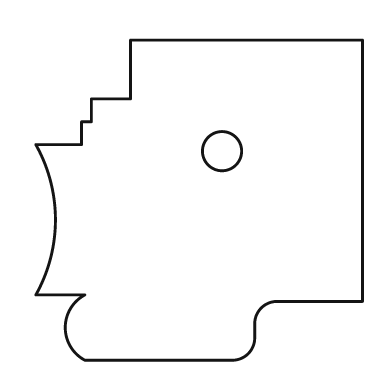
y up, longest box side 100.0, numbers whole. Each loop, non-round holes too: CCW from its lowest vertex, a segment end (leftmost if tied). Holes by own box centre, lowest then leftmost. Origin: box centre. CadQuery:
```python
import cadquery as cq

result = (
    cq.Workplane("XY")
    .moveTo(-35.0, -49.0)
    .lineTo(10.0, -49.0)
    .threePointArc((15.0, -47.0), (17.0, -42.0))
    .lineTo(17.0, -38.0)
    .threePointArc((19.0, -33.0), (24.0, -31.0))
    .lineTo(50.0, -31.0)
    .lineTo(50.0, 49.0)
    .lineTo(-21.0, 49.0)
    .lineTo(-21.0, 31.0)
    .lineTo(-33.0, 31.0)
    .lineTo(-33.0, 24.0)
    .lineTo(-36.0, 24.0)
    .lineTo(-36.0, 17.0)
    .lineTo(-50.0, 17.0)
    .threePointArc((-44.0, -6.0), (-50.0, -29.0))
    .lineTo(-35.0, -29.0)
    .threePointArc((-41.0, -39.0), (-35.0, -49.0))
    .close()
    .moveTo(7.0, 15.0)
    .circle(6.0)
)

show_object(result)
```